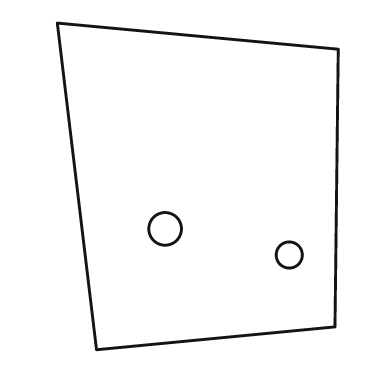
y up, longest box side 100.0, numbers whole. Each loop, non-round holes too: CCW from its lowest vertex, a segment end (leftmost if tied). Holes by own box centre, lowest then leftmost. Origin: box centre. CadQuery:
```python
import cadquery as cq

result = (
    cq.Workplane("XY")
    .moveTo(-31.0, -50.0)
    .lineTo(42.0, -43.0)
    .lineTo(43.0, 42.0)
    .lineTo(-43.0, 50.0)
    .close()
    .moveTo(28.0, -21.0)
    .circle(4.0)
    .moveTo(-10.0, -13.0)
    .circle(5.0)
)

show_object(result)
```